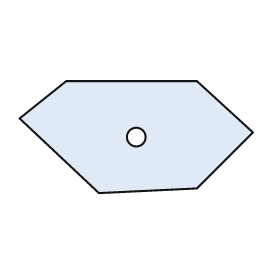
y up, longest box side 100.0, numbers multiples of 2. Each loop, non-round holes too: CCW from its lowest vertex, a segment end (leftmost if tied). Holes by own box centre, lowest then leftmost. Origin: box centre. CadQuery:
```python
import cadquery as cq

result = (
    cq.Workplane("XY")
    .moveTo(-16.0, -24.0)
    .lineTo(26.0, -22.0)
    .lineTo(50.0, 2.0)
    .lineTo(26.0, 24.0)
    .lineTo(-30.0, 24.0)
    .lineTo(-50.0, 8.0)
    .close()
    .moveTo(0.0, 0.0)
    .circle(4.0)
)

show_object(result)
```